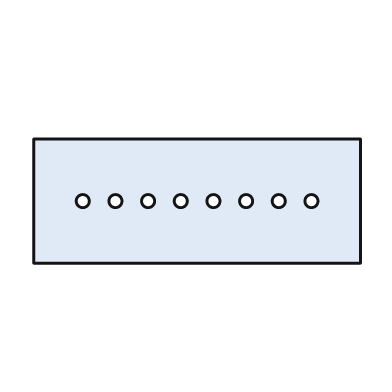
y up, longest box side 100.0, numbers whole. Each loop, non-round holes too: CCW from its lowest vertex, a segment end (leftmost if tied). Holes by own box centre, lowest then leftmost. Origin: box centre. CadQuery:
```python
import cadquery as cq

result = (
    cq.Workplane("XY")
    .moveTo(-50.0, -19.0)
    .lineTo(50.0, -19.0)
    .lineTo(50.0, 19.0)
    .lineTo(-50.0, 19.0)
    .close()
    .moveTo(-35.0, 0.0)
    .circle(2.0)
    .moveTo(-25.0, 0.0)
    .circle(2.0)
    .moveTo(-15.0, 0.0)
    .circle(2.0)
    .moveTo(-5.0, 0.0)
    .circle(2.0)
    .moveTo(5.0, 0.0)
    .circle(2.0)
    .moveTo(15.0, 0.0)
    .circle(2.0)
    .moveTo(25.0, 0.0)
    .circle(2.0)
    .moveTo(35.0, 0.0)
    .circle(2.0)
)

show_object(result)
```